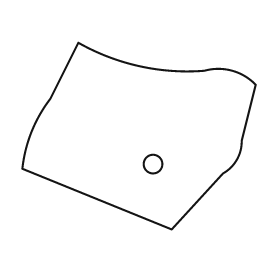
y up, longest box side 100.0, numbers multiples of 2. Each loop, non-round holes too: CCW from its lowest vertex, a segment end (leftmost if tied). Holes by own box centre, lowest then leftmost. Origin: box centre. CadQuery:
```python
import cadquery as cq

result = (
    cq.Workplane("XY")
    .moveTo(14.0, -40.0)
    .lineTo(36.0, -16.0)
    .threePointArc((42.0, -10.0), (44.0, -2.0))
    .lineTo(50.0, 22.0)
    .threePointArc((40.0, 28.0), (28.0, 28.0))
    .threePointArc((0.0, 30.0), (-26.0, 40.0))
    .lineTo(-38.0, 16.0)
    .threePointArc((-46.0, 2.0), (-50.0, -14.0))
    .close()
    .moveTo(6.0, -12.0)
    .circle(4.0)
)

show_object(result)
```